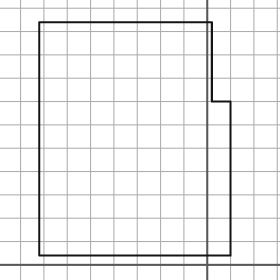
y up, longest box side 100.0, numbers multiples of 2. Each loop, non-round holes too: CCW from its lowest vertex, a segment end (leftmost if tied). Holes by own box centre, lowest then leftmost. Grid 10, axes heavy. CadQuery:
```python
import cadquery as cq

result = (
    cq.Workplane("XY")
    .moveTo(-72.0, 4.0)
    .lineTo(10.0, 4.0)
    .lineTo(10.0, 70.0)
    .lineTo(2.0, 70.0)
    .lineTo(2.0, 104.0)
    .lineTo(-72.0, 104.0)
    .close()
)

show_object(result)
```